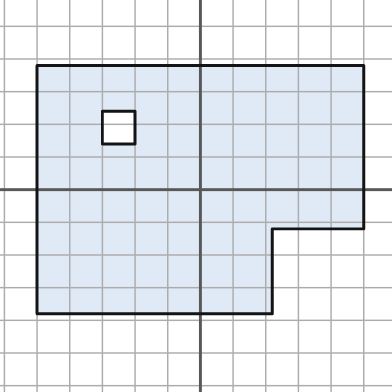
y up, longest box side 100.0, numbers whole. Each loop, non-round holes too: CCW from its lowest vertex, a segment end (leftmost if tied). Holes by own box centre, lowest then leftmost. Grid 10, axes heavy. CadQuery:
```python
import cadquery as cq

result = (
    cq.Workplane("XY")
    .moveTo(-50.0, -38.0)
    .lineTo(22.0, -38.0)
    .lineTo(22.0, -12.0)
    .lineTo(50.0, -12.0)
    .lineTo(50.0, 38.0)
    .lineTo(-50.0, 38.0)
    .close()
    .moveTo(-30.0, 14.0)
    .lineTo(-20.0, 14.0)
    .lineTo(-20.0, 24.0)
    .lineTo(-30.0, 24.0)
    .close()
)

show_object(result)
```